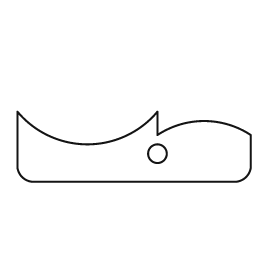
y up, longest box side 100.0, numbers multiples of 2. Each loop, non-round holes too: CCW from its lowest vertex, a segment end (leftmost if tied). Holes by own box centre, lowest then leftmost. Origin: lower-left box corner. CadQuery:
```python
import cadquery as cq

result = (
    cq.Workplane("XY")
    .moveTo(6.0, 0.0)
    .lineTo(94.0, 0.0)
    .threePointArc((98.0, 2.0), (100.0, 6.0))
    .lineTo(100.0, 20.0)
    .threePointArc((80.0, 26.0), (60.0, 20.0))
    .lineTo(60.0, 30.0)
    .threePointArc((30.0, 16.0), (0.0, 30.0))
    .lineTo(0.0, 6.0)
    .threePointArc((2.0, 2.0), (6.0, 0.0))
    .close()
    .moveTo(60.0, 12.0)
    .circle(4.0)
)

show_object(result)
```